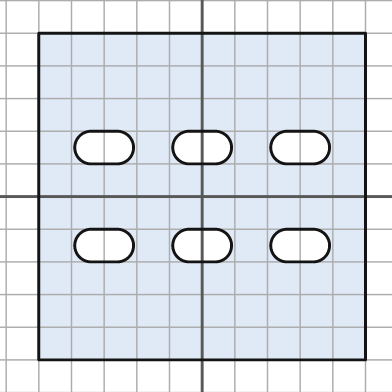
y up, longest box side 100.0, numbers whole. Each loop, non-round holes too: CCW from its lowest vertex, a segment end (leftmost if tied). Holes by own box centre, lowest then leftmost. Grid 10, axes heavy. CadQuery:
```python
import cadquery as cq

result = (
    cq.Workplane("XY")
    .moveTo(-50.0, -50.0)
    .lineTo(50.0, -50.0)
    .lineTo(50.0, 50.0)
    .lineTo(-50.0, 50.0)
    .close()
    .moveTo(-34.0, -20.0)
    .lineTo(-26.0, -20.0)
    .threePointArc((-21.0, -15.0), (-26.0, -10.0))
    .lineTo(-34.0, -10.0)
    .threePointArc((-39.0, -15.0), (-34.0, -20.0))
    .close()
    .moveTo(-4.0, -20.0)
    .lineTo(4.0, -20.0)
    .threePointArc((9.0, -15.0), (4.0, -10.0))
    .lineTo(-4.0, -10.0)
    .threePointArc((-9.0, -15.0), (-4.0, -20.0))
    .close()
    .moveTo(26.0, -20.0)
    .lineTo(34.0, -20.0)
    .threePointArc((39.0, -15.0), (34.0, -10.0))
    .lineTo(26.0, -10.0)
    .threePointArc((21.0, -15.0), (26.0, -20.0))
    .close()
    .moveTo(-34.0, 10.0)
    .lineTo(-26.0, 10.0)
    .threePointArc((-21.0, 15.0), (-26.0, 20.0))
    .lineTo(-34.0, 20.0)
    .threePointArc((-39.0, 15.0), (-34.0, 10.0))
    .close()
    .moveTo(-4.0, 10.0)
    .lineTo(4.0, 10.0)
    .threePointArc((9.0, 15.0), (4.0, 20.0))
    .lineTo(-4.0, 20.0)
    .threePointArc((-9.0, 15.0), (-4.0, 10.0))
    .close()
    .moveTo(26.0, 10.0)
    .lineTo(34.0, 10.0)
    .threePointArc((39.0, 15.0), (34.0, 20.0))
    .lineTo(26.0, 20.0)
    .threePointArc((21.0, 15.0), (26.0, 10.0))
    .close()
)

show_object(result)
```